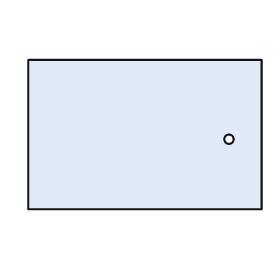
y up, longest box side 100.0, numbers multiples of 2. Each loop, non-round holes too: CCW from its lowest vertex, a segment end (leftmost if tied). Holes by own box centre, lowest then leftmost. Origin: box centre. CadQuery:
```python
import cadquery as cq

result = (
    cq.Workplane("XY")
    .moveTo(-50.0, -32.0)
    .lineTo(50.0, -32.0)
    .lineTo(50.0, 32.0)
    .lineTo(-50.0, 32.0)
    .close()
    .moveTo(36.0, -2.0)
    .circle(2.0)
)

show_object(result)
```